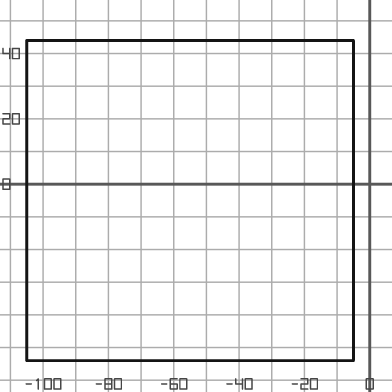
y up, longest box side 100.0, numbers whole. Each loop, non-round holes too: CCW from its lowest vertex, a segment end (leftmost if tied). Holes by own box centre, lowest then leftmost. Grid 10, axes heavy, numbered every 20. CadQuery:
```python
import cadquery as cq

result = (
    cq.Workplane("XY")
    .moveTo(-105.0, -54.0)
    .lineTo(-5.0, -54.0)
    .lineTo(-5.0, 44.0)
    .lineTo(-105.0, 44.0)
    .close()
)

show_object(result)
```